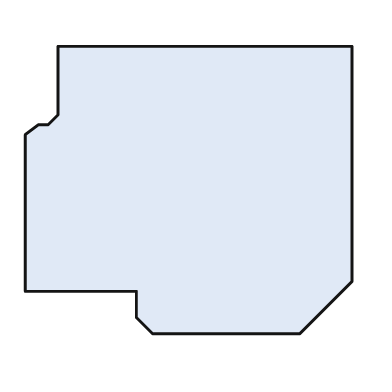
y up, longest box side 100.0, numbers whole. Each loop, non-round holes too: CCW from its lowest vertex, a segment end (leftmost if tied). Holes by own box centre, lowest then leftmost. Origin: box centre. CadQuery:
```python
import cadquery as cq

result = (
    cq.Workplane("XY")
    .moveTo(-11.0, -44.0)
    .lineTo(34.0, -44.0)
    .lineTo(50.0, -28.0)
    .lineTo(50.0, 44.0)
    .lineTo(-40.0, 44.0)
    .lineTo(-40.0, 23.0)
    .lineTo(-43.0, 20.0)
    .lineTo(-46.0, 20.0)
    .lineTo(-50.0, 17.0)
    .lineTo(-50.0, -31.0)
    .lineTo(-16.0, -31.0)
    .lineTo(-16.0, -39.0)
    .close()
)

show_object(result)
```